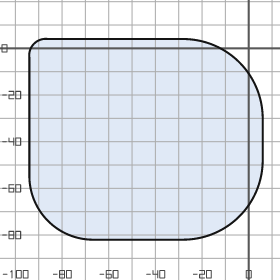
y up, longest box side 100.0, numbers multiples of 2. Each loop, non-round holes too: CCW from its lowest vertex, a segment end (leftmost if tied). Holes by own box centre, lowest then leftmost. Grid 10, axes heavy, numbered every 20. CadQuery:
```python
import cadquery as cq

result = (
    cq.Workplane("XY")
    .moveTo(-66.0, -82.0)
    .lineTo(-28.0, -82.0)
    .threePointArc((-4.0, -72.0), (6.0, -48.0))
    .lineTo(6.0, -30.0)
    .threePointArc((-4.0, -6.0), (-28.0, 4.0))
    .lineTo(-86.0, 4.0)
    .threePointArc((-92.0, 2.0), (-94.0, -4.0))
    .lineTo(-94.0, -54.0)
    .threePointArc((-86.0, -74.0), (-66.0, -82.0))
    .close()
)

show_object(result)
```